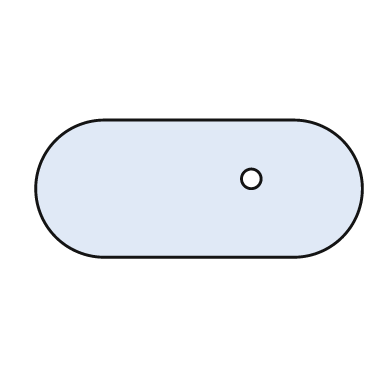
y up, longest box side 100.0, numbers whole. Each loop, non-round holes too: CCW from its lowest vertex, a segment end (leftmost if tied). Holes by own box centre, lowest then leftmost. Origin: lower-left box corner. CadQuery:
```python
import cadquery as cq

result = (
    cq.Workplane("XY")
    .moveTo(21.0, 0.0)
    .lineTo(79.0, 0.0)
    .threePointArc((100.0, 21.0), (79.0, 42.0))
    .lineTo(21.0, 42.0)
    .threePointArc((0.0, 21.0), (21.0, 0.0))
    .close()
    .moveTo(66.0, 24.0)
    .circle(3.0)
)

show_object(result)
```